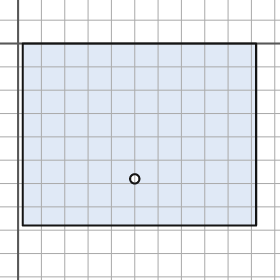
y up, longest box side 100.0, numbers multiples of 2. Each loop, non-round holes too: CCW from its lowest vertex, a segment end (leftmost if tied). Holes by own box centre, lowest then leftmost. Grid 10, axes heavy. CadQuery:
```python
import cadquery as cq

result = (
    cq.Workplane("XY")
    .moveTo(2.0, -78.0)
    .lineTo(102.0, -78.0)
    .lineTo(102.0, 0.0)
    .lineTo(2.0, 0.0)
    .close()
    .moveTo(50.0, -58.0)
    .circle(2.0)
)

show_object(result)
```